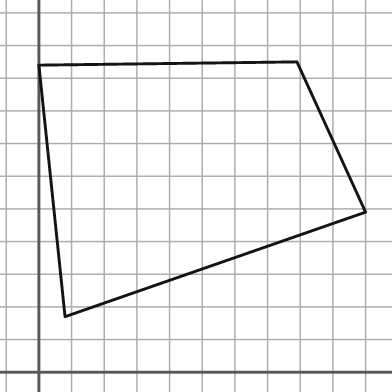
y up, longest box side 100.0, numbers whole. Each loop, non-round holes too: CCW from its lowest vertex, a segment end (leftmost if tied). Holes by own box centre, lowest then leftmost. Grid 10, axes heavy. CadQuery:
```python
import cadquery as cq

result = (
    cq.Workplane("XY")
    .moveTo(8.0, 17.0)
    .lineTo(100.0, 49.0)
    .lineTo(79.0, 95.0)
    .lineTo(0.0, 94.0)
    .close()
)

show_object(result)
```